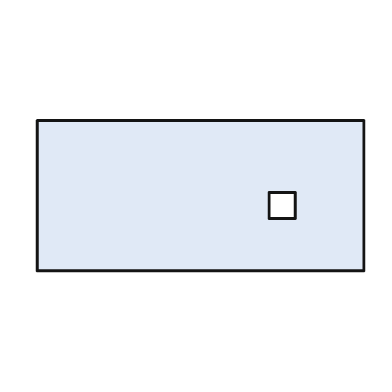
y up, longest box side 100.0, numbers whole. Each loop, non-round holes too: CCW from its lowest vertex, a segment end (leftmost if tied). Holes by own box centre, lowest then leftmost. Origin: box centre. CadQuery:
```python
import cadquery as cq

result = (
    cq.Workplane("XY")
    .moveTo(-50.0, -23.0)
    .lineTo(50.0, -23.0)
    .lineTo(50.0, 23.0)
    .lineTo(-50.0, 23.0)
    .close()
    .moveTo(21.0, -7.0)
    .lineTo(29.0, -7.0)
    .lineTo(29.0, 1.0)
    .lineTo(21.0, 1.0)
    .close()
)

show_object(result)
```